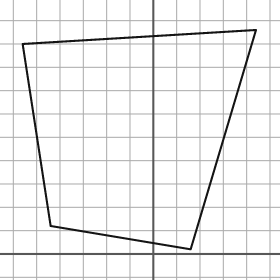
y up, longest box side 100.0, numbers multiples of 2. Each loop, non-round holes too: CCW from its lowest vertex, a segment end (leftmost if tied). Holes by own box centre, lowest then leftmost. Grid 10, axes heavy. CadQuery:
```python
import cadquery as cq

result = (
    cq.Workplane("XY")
    .moveTo(16.0, 2.0)
    .lineTo(44.0, 96.0)
    .lineTo(-56.0, 90.0)
    .lineTo(-44.0, 12.0)
    .close()
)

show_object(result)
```